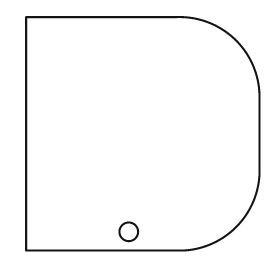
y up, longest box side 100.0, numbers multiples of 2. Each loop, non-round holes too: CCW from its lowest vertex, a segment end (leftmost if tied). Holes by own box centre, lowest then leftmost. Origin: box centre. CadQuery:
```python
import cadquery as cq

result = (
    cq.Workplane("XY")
    .moveTo(-50.0, -50.0)
    .lineTo(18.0, -50.0)
    .threePointArc((40.0, -40.0), (50.0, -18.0))
    .lineTo(50.0, 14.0)
    .threePointArc((40.0, 40.0), (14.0, 50.0))
    .lineTo(-50.0, 50.0)
    .close()
    .moveTo(-6.0, -42.0)
    .circle(4.0)
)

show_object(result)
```